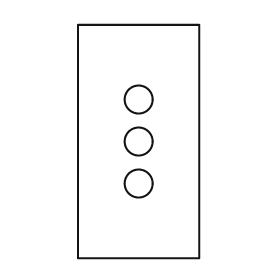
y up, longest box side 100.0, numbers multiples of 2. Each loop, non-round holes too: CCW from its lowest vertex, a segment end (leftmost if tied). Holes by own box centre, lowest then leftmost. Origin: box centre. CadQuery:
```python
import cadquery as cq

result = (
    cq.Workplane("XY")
    .moveTo(-26.0, -50.0)
    .lineTo(26.0, -50.0)
    .lineTo(26.0, 50.0)
    .lineTo(-26.0, 50.0)
    .close()
    .moveTo(0.0, -18.0)
    .circle(6.0)
    .moveTo(0.0, 0.0)
    .circle(6.0)
    .moveTo(0.0, 18.0)
    .circle(6.0)
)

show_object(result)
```